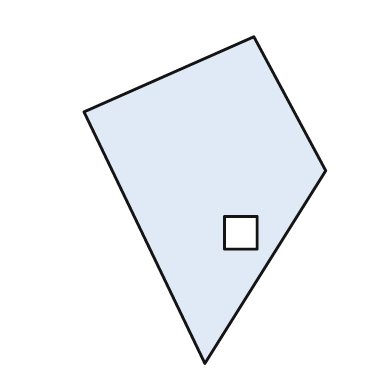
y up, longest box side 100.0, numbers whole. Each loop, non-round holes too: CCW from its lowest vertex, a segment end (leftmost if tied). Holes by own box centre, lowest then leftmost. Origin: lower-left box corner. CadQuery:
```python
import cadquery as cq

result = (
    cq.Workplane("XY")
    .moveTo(37.0, 0.0)
    .lineTo(74.0, 59.0)
    .lineTo(52.0, 100.0)
    .lineTo(0.0, 77.0)
    .close()
    .moveTo(43.0, 35.0)
    .lineTo(53.0, 35.0)
    .lineTo(53.0, 45.0)
    .lineTo(43.0, 45.0)
    .close()
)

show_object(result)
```